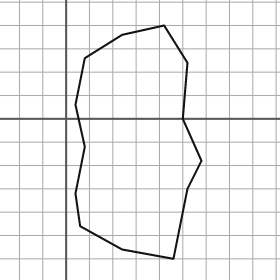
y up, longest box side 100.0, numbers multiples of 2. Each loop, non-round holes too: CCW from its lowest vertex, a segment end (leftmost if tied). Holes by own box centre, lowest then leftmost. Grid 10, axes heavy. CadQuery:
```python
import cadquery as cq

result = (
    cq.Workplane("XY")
    .moveTo(46.0, -60.0)
    .lineTo(52.0, -30.0)
    .lineTo(58.0, -18.0)
    .lineTo(50.0, 0.0)
    .lineTo(52.0, 24.0)
    .lineTo(42.0, 40.0)
    .lineTo(24.0, 36.0)
    .lineTo(8.0, 26.0)
    .lineTo(4.0, 6.0)
    .lineTo(8.0, -12.0)
    .lineTo(4.0, -32.0)
    .lineTo(6.0, -46.0)
    .lineTo(24.0, -56.0)
    .close()
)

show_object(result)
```